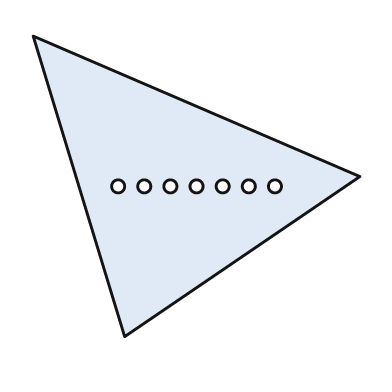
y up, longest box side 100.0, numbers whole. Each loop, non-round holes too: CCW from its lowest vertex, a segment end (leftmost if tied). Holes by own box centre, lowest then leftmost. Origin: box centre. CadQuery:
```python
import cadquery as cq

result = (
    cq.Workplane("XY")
    .moveTo(-22.0, -46.0)
    .lineTo(50.0, 3.0)
    .lineTo(-50.0, 46.0)
    .close()
    .moveTo(-24.0, 0.0)
    .circle(2.0)
    .moveTo(-16.0, 0.0)
    .circle(2.0)
    .moveTo(-8.0, 0.0)
    .circle(2.0)
    .moveTo(0.0, 0.0)
    .circle(2.0)
    .moveTo(8.0, 0.0)
    .circle(2.0)
    .moveTo(16.0, 0.0)
    .circle(2.0)
    .moveTo(24.0, 0.0)
    .circle(2.0)
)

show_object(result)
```